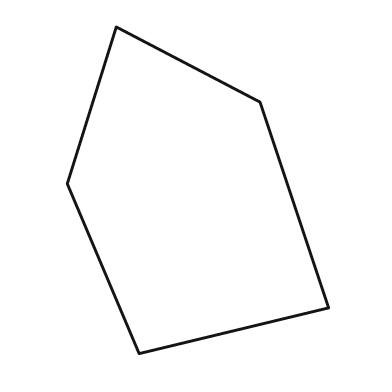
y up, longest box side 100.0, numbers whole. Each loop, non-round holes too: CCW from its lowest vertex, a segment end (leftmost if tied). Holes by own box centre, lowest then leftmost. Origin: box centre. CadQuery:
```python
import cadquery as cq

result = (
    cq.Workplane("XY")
    .moveTo(-18.0, -50.0)
    .lineTo(40.0, -36.0)
    .lineTo(19.0, 27.0)
    .lineTo(-25.0, 50.0)
    .lineTo(-40.0, 2.0)
    .close()
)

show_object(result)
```